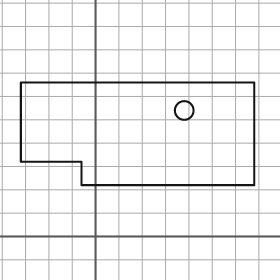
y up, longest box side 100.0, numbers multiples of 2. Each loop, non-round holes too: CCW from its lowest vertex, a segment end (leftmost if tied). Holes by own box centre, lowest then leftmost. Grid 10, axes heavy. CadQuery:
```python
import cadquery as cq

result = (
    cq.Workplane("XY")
    .moveTo(-6.0, 22.0)
    .lineTo(68.0, 22.0)
    .lineTo(68.0, 66.0)
    .lineTo(-32.0, 66.0)
    .lineTo(-32.0, 32.0)
    .lineTo(-6.0, 32.0)
    .close()
    .moveTo(38.0, 54.0)
    .circle(4.0)
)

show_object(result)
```